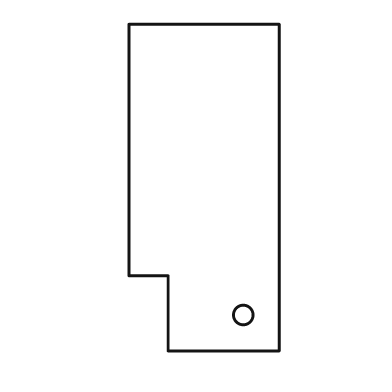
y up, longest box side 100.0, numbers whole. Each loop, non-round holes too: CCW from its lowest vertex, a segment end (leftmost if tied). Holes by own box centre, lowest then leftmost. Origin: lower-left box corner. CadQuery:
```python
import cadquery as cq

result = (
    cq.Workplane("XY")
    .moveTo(12.0, 0.0)
    .lineTo(46.0, 0.0)
    .lineTo(46.0, 100.0)
    .lineTo(0.0, 100.0)
    .lineTo(0.0, 23.0)
    .lineTo(12.0, 23.0)
    .close()
    .moveTo(35.0, 11.0)
    .circle(3.0)
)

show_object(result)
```